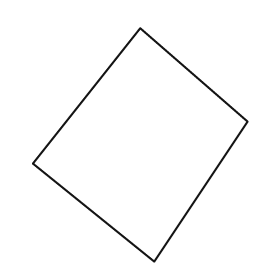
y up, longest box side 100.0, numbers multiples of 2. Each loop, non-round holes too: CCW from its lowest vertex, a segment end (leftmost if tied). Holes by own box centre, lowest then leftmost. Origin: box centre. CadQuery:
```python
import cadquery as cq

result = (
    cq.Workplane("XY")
    .moveTo(6.0, -50.0)
    .lineTo(46.0, 10.0)
    .lineTo(0.0, 50.0)
    .lineTo(-46.0, -8.0)
    .close()
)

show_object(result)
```